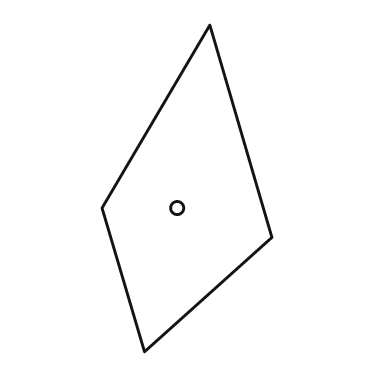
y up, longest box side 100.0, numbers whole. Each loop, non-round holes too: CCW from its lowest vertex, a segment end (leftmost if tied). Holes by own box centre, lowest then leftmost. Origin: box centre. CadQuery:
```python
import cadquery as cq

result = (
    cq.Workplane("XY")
    .moveTo(-13.0, -50.0)
    .lineTo(26.0, -15.0)
    .lineTo(7.0, 50.0)
    .lineTo(-26.0, -6.0)
    .close()
    .moveTo(-3.0, -6.0)
    .circle(2.0)
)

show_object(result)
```